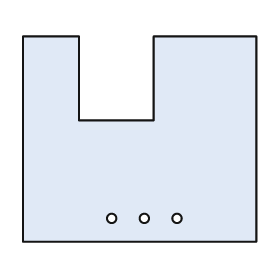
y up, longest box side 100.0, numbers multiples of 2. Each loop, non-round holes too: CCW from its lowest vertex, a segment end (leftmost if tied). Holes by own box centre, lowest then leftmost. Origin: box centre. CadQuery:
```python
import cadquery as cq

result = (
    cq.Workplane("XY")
    .moveTo(-50.0, -44.0)
    .lineTo(50.0, -44.0)
    .lineTo(50.0, 44.0)
    .lineTo(6.0, 44.0)
    .lineTo(6.0, 8.0)
    .lineTo(-26.0, 8.0)
    .lineTo(-26.0, 44.0)
    .lineTo(-50.0, 44.0)
    .close()
    .moveTo(-12.0, -34.0)
    .circle(2.0)
    .moveTo(2.0, -34.0)
    .circle(2.0)
    .moveTo(16.0, -34.0)
    .circle(2.0)
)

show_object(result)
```